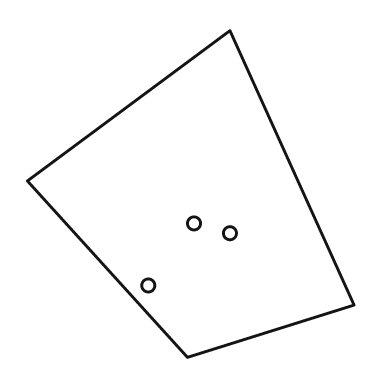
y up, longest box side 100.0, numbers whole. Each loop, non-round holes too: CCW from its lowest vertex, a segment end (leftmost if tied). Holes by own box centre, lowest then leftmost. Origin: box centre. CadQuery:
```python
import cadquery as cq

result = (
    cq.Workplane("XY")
    .moveTo(-1.0, -50.0)
    .lineTo(50.0, -34.0)
    .lineTo(12.0, 50.0)
    .lineTo(-50.0, 4.0)
    .close()
    .moveTo(-13.0, -28.0)
    .circle(2.0)
    .moveTo(12.0, -12.0)
    .circle(2.0)
    .moveTo(1.0, -9.0)
    .circle(2.0)
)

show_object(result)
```